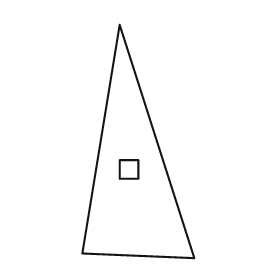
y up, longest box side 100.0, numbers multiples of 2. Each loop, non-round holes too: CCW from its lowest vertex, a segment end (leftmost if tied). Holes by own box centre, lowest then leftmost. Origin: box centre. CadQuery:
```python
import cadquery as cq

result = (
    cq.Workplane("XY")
    .moveTo(24.0, -50.0)
    .lineTo(-8.0, 50.0)
    .lineTo(-24.0, -48.0)
    .close()
    .moveTo(-8.0, -16.0)
    .lineTo(0.0, -16.0)
    .lineTo(0.0, -8.0)
    .lineTo(-8.0, -8.0)
    .close()
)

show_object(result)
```